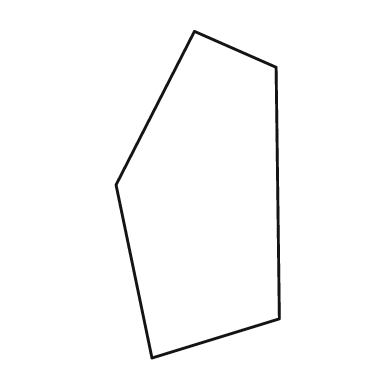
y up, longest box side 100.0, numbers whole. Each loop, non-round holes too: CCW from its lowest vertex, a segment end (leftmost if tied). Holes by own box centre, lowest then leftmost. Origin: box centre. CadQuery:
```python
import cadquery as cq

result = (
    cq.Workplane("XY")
    .moveTo(-14.0, -50.0)
    .lineTo(25.0, -38.0)
    .lineTo(24.0, 39.0)
    .lineTo(-1.0, 50.0)
    .lineTo(-25.0, 3.0)
    .close()
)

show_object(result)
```